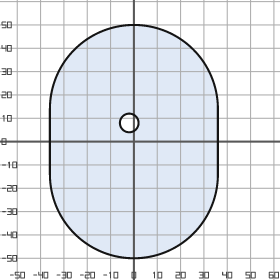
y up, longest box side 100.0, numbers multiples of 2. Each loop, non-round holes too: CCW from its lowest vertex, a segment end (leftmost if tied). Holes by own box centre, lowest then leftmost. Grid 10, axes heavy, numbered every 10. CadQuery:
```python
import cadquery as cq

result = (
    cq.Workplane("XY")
    .moveTo(-36.0, -14.0)
    .threePointArc((0.0, -50.0), (36.0, -14.0))
    .lineTo(36.0, 14.0)
    .threePointArc((0.0, 50.0), (-36.0, 14.0))
    .close()
    .moveTo(-2.0, 8.0)
    .circle(4.0)
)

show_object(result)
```